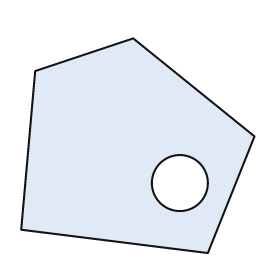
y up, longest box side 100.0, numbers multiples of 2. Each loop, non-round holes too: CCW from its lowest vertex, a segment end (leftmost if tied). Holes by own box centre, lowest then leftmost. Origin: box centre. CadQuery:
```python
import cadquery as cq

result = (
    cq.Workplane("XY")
    .moveTo(30.0, -46.0)
    .lineTo(50.0, 4.0)
    .lineTo(-2.0, 46.0)
    .lineTo(-44.0, 32.0)
    .lineTo(-50.0, -36.0)
    .close()
    .moveTo(18.0, -16.0)
    .circle(12.0)
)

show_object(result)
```